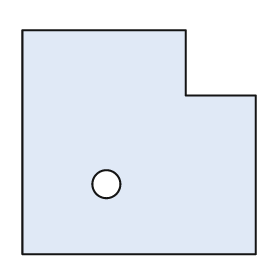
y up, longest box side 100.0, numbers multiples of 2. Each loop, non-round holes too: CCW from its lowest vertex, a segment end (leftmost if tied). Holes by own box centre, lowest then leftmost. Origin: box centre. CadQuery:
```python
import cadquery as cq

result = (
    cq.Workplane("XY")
    .moveTo(-50.0, -48.0)
    .lineTo(50.0, -48.0)
    .lineTo(50.0, 20.0)
    .lineTo(20.0, 20.0)
    .lineTo(20.0, 48.0)
    .lineTo(-50.0, 48.0)
    .close()
    .moveTo(-14.0, -18.0)
    .circle(6.0)
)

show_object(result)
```